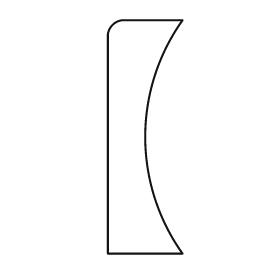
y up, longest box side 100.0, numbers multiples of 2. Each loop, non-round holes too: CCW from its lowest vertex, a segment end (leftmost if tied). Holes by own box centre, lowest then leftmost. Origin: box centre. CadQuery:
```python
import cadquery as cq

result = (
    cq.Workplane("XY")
    .moveTo(-16.0, -50.0)
    .lineTo(16.0, -50.0)
    .threePointArc((0.0, 0.0), (16.0, 50.0))
    .lineTo(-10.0, 50.0)
    .threePointArc((-14.0, 48.0), (-16.0, 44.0))
    .close()
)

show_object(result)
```